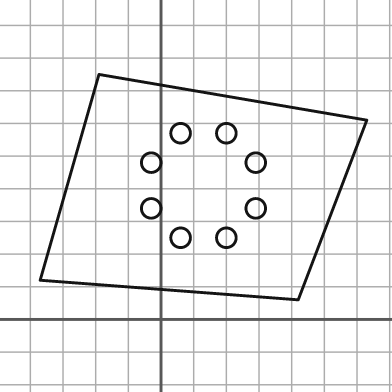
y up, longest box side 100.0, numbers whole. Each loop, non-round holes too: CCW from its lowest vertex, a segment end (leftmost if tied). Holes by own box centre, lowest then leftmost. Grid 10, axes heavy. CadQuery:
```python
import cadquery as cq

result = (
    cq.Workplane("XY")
    .moveTo(42.0, 6.0)
    .lineTo(63.0, 61.0)
    .lineTo(-19.0, 75.0)
    .lineTo(-37.0, 12.0)
    .close()
    .moveTo(6.0, 25.0)
    .circle(3.0)
    .moveTo(20.0, 25.0)
    .circle(3.0)
    .moveTo(-3.0, 34.0)
    .circle(3.0)
    .moveTo(29.0, 34.0)
    .circle(3.0)
    .moveTo(-3.0, 48.0)
    .circle(3.0)
    .moveTo(29.0, 48.0)
    .circle(3.0)
    .moveTo(6.0, 57.0)
    .circle(3.0)
    .moveTo(20.0, 57.0)
    .circle(3.0)
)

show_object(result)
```